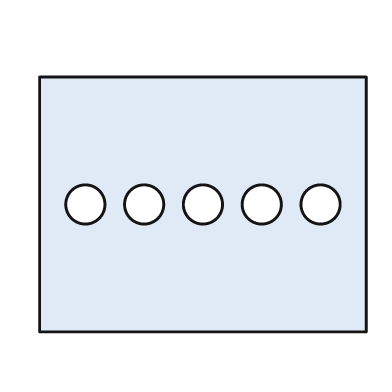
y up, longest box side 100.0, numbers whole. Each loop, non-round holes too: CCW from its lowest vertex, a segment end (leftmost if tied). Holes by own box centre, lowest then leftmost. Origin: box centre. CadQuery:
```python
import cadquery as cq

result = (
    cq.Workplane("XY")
    .moveTo(-50.0, -39.0)
    .lineTo(50.0, -39.0)
    .lineTo(50.0, 39.0)
    .lineTo(-50.0, 39.0)
    .close()
    .moveTo(-36.0, 0.0)
    .circle(6.0)
    .moveTo(-18.0, 0.0)
    .circle(6.0)
    .moveTo(0.0, 0.0)
    .circle(6.0)
    .moveTo(18.0, 0.0)
    .circle(6.0)
    .moveTo(36.0, 0.0)
    .circle(6.0)
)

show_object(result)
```